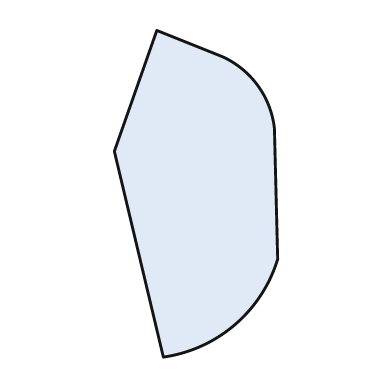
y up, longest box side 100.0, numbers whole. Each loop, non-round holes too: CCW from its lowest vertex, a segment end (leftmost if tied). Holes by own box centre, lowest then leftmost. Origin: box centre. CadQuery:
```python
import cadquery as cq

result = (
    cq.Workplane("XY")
    .moveTo(-10.0, -50.0)
    .threePointArc((12.0, -40.0), (25.0, -20.0))
    .lineTo(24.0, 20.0)
    .threePointArc((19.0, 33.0), (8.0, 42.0))
    .lineTo(-12.0, 50.0)
    .lineTo(-25.0, 13.0)
    .close()
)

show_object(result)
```